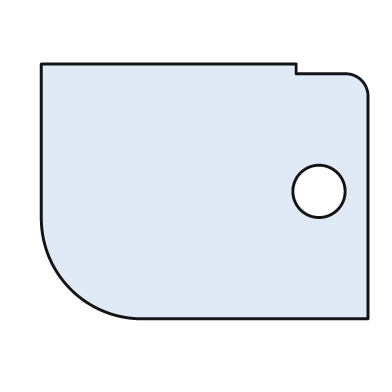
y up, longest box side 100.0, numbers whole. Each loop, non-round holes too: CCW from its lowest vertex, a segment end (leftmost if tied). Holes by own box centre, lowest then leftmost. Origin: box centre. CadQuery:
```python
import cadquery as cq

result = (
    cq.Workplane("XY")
    .moveTo(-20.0, -39.0)
    .lineTo(50.0, -39.0)
    .lineTo(50.0, 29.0)
    .threePointArc((48.0, 34.0), (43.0, 36.0))
    .lineTo(28.0, 36.0)
    .lineTo(28.0, 39.0)
    .lineTo(-50.0, 39.0)
    .lineTo(-50.0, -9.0)
    .threePointArc((-41.0, -30.0), (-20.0, -39.0))
    .close()
    .moveTo(35.0, 0.0)
    .circle(8.0)
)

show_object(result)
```